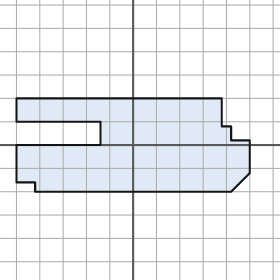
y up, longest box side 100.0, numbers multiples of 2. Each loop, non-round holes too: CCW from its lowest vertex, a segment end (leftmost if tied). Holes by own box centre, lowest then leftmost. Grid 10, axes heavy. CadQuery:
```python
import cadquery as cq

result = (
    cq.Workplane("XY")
    .moveTo(-42.0, -20.0)
    .lineTo(42.0, -20.0)
    .lineTo(50.0, -12.0)
    .lineTo(50.0, 2.0)
    .lineTo(42.0, 2.0)
    .lineTo(42.0, 8.0)
    .lineTo(38.0, 8.0)
    .lineTo(38.0, 20.0)
    .lineTo(-50.0, 20.0)
    .lineTo(-50.0, 10.0)
    .lineTo(-14.0, 10.0)
    .lineTo(-14.0, 0.0)
    .lineTo(-50.0, 0.0)
    .lineTo(-50.0, -16.0)
    .lineTo(-42.0, -16.0)
    .close()
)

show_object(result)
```